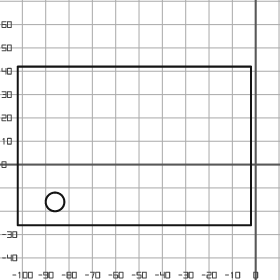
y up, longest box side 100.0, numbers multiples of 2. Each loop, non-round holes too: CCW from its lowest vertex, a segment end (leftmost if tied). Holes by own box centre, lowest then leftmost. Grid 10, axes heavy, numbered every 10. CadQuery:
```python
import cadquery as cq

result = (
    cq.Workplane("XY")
    .moveTo(-102.0, -26.0)
    .lineTo(-2.0, -26.0)
    .lineTo(-2.0, 42.0)
    .lineTo(-102.0, 42.0)
    .close()
    .moveTo(-86.0, -16.0)
    .circle(4.0)
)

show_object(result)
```